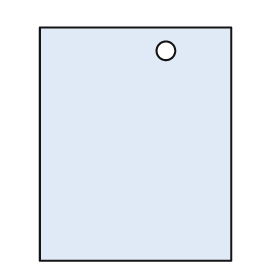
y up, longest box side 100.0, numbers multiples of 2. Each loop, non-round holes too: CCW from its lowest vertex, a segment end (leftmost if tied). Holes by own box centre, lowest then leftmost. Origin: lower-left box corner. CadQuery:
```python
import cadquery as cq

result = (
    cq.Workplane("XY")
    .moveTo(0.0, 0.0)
    .lineTo(82.0, 0.0)
    .lineTo(82.0, 100.0)
    .lineTo(0.0, 100.0)
    .close()
    .moveTo(54.0, 90.0)
    .circle(4.0)
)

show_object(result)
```